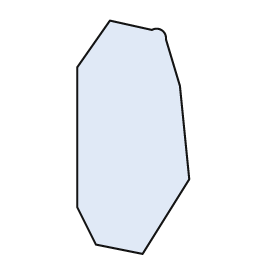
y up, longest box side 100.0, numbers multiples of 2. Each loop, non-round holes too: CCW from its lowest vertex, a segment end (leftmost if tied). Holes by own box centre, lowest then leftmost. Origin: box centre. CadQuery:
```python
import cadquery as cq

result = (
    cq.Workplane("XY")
    .moveTo(4.0, -50.0)
    .lineTo(24.0, -18.0)
    .lineTo(20.0, 22.0)
    .lineTo(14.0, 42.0)
    .threePointArc((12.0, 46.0), (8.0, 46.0))
    .lineTo(-10.0, 50.0)
    .lineTo(-24.0, 30.0)
    .lineTo(-24.0, -30.0)
    .lineTo(-16.0, -46.0)
    .close()
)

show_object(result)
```